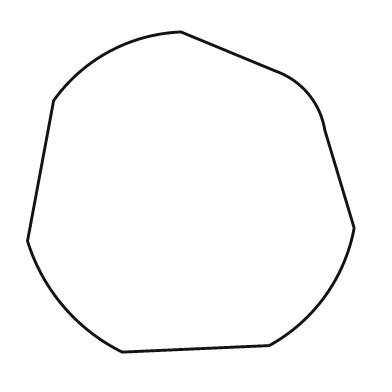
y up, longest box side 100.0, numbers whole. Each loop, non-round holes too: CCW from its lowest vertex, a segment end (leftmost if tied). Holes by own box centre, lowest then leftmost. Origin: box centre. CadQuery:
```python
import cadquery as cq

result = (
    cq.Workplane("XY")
    .moveTo(-21.0, -49.0)
    .lineTo(24.0, -47.0)
    .threePointArc((41.0, -32.0), (50.0, -11.0))
    .lineTo(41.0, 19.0)
    .threePointArc((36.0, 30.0), (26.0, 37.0))
    .lineTo(-3.0, 49.0)
    .threePointArc((-25.0, 43.0), (-42.0, 28.0))
    .lineTo(-50.0, -15.0)
    .threePointArc((-39.0, -35.0), (-21.0, -49.0))
    .close()
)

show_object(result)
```